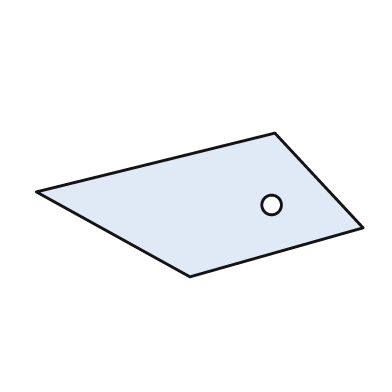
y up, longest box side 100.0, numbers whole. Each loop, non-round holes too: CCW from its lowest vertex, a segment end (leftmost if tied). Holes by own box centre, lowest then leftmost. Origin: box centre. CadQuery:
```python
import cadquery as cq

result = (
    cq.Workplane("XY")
    .moveTo(-3.0, -22.0)
    .lineTo(50.0, -7.0)
    .lineTo(23.0, 22.0)
    .lineTo(-50.0, 4.0)
    .close()
    .moveTo(22.0, 0.0)
    .circle(3.0)
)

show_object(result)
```